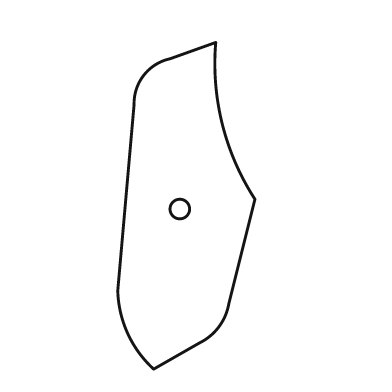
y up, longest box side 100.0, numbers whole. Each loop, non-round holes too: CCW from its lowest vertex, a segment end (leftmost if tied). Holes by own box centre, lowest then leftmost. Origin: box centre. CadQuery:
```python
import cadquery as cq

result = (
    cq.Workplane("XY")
    .moveTo(-10.0, -50.0)
    .lineTo(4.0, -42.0)
    .threePointArc((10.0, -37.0), (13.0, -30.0))
    .lineTo(21.0, 2.0)
    .threePointArc((11.0, 25.0), (9.0, 50.0))
    .lineTo(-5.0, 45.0)
    .threePointArc((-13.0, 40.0), (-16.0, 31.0))
    .lineTo(-21.0, -26.0)
    .threePointArc((-18.0, -39.0), (-10.0, -50.0))
    .close()
    .moveTo(-2.0, -1.0)
    .circle(3.0)
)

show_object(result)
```